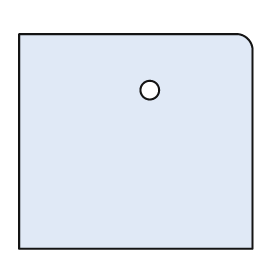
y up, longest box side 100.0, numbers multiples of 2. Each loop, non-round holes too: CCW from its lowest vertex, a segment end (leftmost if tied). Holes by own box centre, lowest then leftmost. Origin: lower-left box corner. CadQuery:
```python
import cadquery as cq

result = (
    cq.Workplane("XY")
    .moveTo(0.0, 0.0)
    .lineTo(100.0, 0.0)
    .lineTo(100.0, 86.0)
    .threePointArc((98.0, 90.0), (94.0, 92.0))
    .lineTo(0.0, 92.0)
    .close()
    .moveTo(56.0, 68.0)
    .circle(4.0)
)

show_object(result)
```